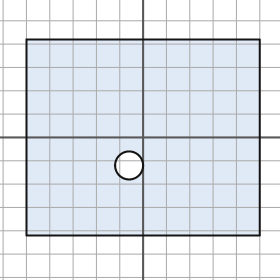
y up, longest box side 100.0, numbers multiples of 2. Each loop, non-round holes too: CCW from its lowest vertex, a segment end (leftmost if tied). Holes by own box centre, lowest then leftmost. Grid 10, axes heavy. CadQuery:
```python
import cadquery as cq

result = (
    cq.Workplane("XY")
    .moveTo(-50.0, -42.0)
    .lineTo(50.0, -42.0)
    .lineTo(50.0, 42.0)
    .lineTo(-50.0, 42.0)
    .close()
    .moveTo(-6.0, -12.0)
    .circle(6.0)
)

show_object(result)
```